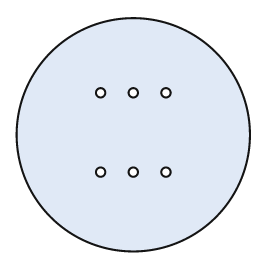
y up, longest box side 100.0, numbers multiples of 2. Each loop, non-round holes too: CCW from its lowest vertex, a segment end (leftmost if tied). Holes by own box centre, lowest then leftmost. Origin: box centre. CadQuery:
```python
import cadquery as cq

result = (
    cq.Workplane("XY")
    .moveTo(0.0, 0.0)
    .circle(50.0)
    .moveTo(-14.0, -16.0)
    .circle(2.0)
    .moveTo(0.0, -16.0)
    .circle(2.0)
    .moveTo(14.0, -16.0)
    .circle(2.0)
    .moveTo(-14.0, 18.0)
    .circle(2.0)
    .moveTo(0.0, 18.0)
    .circle(2.0)
    .moveTo(14.0, 18.0)
    .circle(2.0)
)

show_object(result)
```